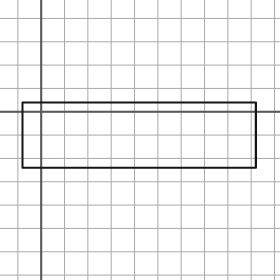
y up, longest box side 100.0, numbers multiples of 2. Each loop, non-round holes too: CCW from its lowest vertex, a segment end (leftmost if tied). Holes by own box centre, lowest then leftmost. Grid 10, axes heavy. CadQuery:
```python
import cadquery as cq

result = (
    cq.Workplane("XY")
    .moveTo(-8.0, -24.0)
    .lineTo(92.0, -24.0)
    .lineTo(92.0, 4.0)
    .lineTo(-8.0, 4.0)
    .close()
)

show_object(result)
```